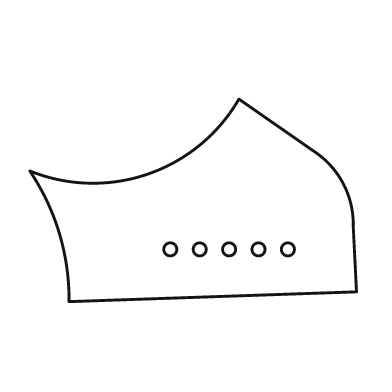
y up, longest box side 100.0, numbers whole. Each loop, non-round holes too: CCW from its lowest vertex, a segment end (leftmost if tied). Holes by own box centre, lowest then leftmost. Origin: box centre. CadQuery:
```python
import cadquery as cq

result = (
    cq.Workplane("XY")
    .moveTo(-38.0, -31.0)
    .lineTo(50.0, -28.0)
    .lineTo(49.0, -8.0)
    .threePointArc((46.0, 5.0), (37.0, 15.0))
    .lineTo(14.0, 31.0)
    .threePointArc((-14.0, 8.0), (-50.0, 9.0))
    .threePointArc((-41.0, -10.0), (-38.0, -31.0))
    .close()
    .moveTo(-7.0, -15.0)
    .circle(2.0)
    .moveTo(2.0, -15.0)
    .circle(2.0)
    .moveTo(11.0, -15.0)
    .circle(2.0)
    .moveTo(20.0, -15.0)
    .circle(2.0)
    .moveTo(29.0, -15.0)
    .circle(2.0)
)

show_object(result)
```